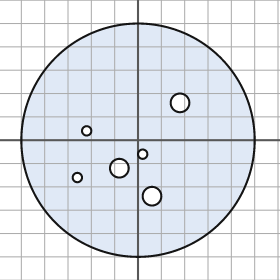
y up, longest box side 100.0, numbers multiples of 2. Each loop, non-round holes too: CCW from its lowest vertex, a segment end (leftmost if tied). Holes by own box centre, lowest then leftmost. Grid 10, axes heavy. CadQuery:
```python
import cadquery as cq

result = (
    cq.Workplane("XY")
    .moveTo(0.0, 0.0)
    .circle(50.0)
    .moveTo(6.0, -24.0)
    .circle(4.0)
    .moveTo(-26.0, -16.0)
    .circle(2.0)
    .moveTo(-8.0, -12.0)
    .circle(4.0)
    .moveTo(2.0, -6.0)
    .circle(2.0)
    .moveTo(-22.0, 4.0)
    .circle(2.0)
    .moveTo(18.0, 16.0)
    .circle(4.0)
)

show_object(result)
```